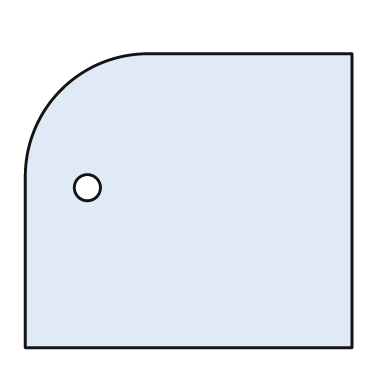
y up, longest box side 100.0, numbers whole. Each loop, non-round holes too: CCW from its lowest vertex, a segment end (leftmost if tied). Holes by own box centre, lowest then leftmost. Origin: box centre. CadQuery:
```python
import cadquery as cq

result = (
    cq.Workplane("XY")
    .moveTo(-50.0, -45.0)
    .lineTo(50.0, -45.0)
    .lineTo(50.0, 45.0)
    .lineTo(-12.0, 45.0)
    .threePointArc((-39.0, 34.0), (-50.0, 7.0))
    .close()
    .moveTo(-31.0, 4.0)
    .circle(4.0)
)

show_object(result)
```